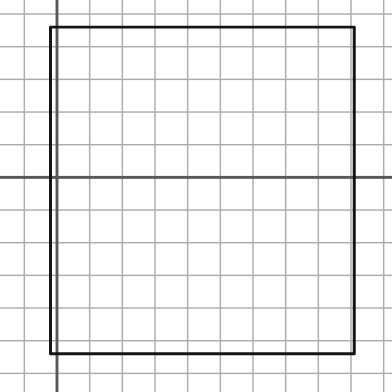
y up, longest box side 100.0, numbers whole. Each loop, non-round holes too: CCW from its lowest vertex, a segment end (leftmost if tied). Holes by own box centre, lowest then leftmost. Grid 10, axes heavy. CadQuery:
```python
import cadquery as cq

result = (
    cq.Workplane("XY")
    .moveTo(-2.0, -54.0)
    .lineTo(91.0, -54.0)
    .lineTo(91.0, 46.0)
    .lineTo(-2.0, 46.0)
    .close()
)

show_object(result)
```